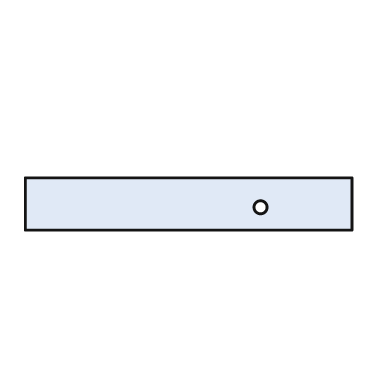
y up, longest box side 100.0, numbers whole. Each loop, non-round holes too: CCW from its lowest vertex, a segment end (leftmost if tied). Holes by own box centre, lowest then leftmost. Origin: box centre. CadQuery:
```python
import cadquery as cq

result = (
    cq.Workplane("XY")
    .moveTo(-50.0, -8.0)
    .lineTo(50.0, -8.0)
    .lineTo(50.0, 8.0)
    .lineTo(-50.0, 8.0)
    .close()
    .moveTo(22.0, -1.0)
    .circle(2.0)
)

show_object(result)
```